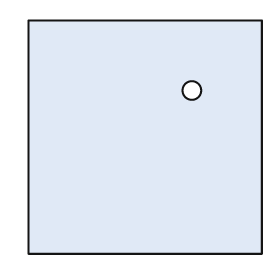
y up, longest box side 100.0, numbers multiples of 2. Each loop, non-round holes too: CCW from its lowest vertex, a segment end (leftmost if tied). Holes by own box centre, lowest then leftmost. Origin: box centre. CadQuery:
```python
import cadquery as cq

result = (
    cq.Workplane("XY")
    .moveTo(-50.0, -50.0)
    .lineTo(50.0, -50.0)
    .lineTo(50.0, 50.0)
    .lineTo(-50.0, 50.0)
    .close()
    .moveTo(20.0, 20.0)
    .circle(4.0)
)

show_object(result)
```